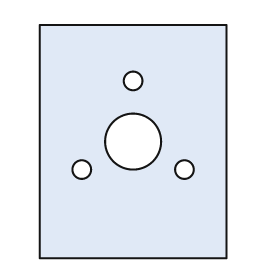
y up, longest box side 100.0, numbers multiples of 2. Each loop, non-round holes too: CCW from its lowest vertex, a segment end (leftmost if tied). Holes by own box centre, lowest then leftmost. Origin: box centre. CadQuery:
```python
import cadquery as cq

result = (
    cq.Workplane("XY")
    .moveTo(-40.0, -50.0)
    .lineTo(40.0, -50.0)
    .lineTo(40.0, 50.0)
    .lineTo(-40.0, 50.0)
    .close()
    .moveTo(-22.0, -12.0)
    .circle(4.0)
    .moveTo(22.0, -12.0)
    .circle(4.0)
    .moveTo(0.0, 0.0)
    .circle(12.0)
    .moveTo(0.0, 26.0)
    .circle(4.0)
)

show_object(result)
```